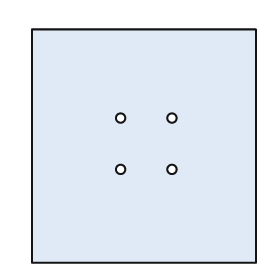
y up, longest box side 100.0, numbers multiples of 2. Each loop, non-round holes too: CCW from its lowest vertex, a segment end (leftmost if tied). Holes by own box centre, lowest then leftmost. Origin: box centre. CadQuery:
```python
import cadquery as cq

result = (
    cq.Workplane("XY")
    .moveTo(-48.0, -50.0)
    .lineTo(48.0, -50.0)
    .lineTo(48.0, 50.0)
    .lineTo(-48.0, 50.0)
    .close()
    .moveTo(-10.0, -10.0)
    .circle(2.0)
    .moveTo(12.0, -10.0)
    .circle(2.0)
    .moveTo(-10.0, 12.0)
    .circle(2.0)
    .moveTo(12.0, 12.0)
    .circle(2.0)
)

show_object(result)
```